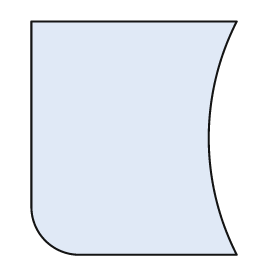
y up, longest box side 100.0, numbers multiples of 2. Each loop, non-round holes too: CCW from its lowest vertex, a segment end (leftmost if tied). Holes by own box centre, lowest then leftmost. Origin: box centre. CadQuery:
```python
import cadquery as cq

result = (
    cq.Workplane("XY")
    .moveTo(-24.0, -50.0)
    .lineTo(44.0, -50.0)
    .threePointArc((32.0, 0.0), (44.0, 50.0))
    .lineTo(-44.0, 50.0)
    .lineTo(-44.0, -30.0)
    .threePointArc((-38.0, -44.0), (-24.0, -50.0))
    .close()
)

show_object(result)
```